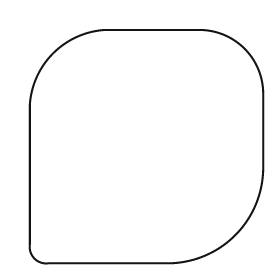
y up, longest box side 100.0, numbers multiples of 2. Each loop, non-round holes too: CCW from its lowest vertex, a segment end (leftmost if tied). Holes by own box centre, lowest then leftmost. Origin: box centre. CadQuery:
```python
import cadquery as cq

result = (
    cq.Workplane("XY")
    .moveTo(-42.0, -50.0)
    .lineTo(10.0, -50.0)
    .threePointArc((38.0, -38.0), (50.0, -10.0))
    .lineTo(50.0, 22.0)
    .threePointArc((42.0, 42.0), (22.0, 50.0))
    .lineTo(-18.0, 50.0)
    .threePointArc((-40.0, 40.0), (-50.0, 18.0))
    .lineTo(-50.0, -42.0)
    .threePointArc((-48.0, -48.0), (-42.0, -50.0))
    .close()
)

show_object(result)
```